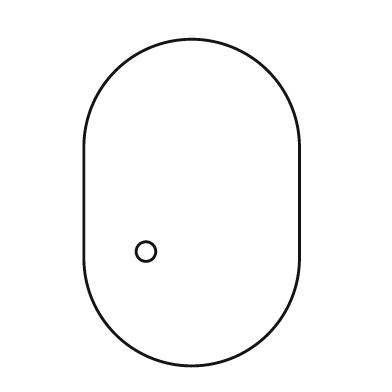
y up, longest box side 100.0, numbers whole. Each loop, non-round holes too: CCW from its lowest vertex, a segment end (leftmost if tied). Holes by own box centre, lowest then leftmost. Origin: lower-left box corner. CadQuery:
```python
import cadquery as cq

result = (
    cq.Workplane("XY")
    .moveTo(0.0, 33.0)
    .threePointArc((33.0, 0.0), (66.0, 33.0))
    .lineTo(66.0, 67.0)
    .threePointArc((33.0, 100.0), (0.0, 67.0))
    .close()
    .moveTo(19.0, 35.0)
    .circle(3.0)
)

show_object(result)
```